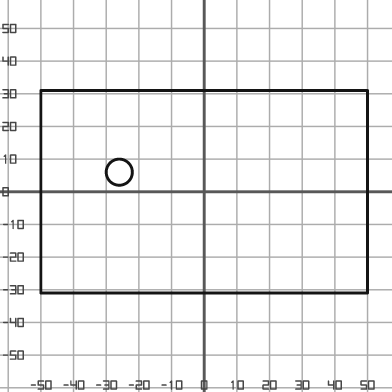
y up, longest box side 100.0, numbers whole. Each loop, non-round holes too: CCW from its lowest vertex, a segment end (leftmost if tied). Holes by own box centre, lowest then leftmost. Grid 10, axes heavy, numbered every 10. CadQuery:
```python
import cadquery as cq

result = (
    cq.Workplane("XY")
    .moveTo(-50.0, -31.0)
    .lineTo(50.0, -31.0)
    .lineTo(50.0, 31.0)
    .lineTo(-50.0, 31.0)
    .close()
    .moveTo(-26.0, 6.0)
    .circle(4.0)
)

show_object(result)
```